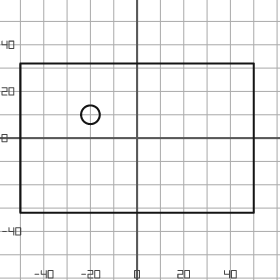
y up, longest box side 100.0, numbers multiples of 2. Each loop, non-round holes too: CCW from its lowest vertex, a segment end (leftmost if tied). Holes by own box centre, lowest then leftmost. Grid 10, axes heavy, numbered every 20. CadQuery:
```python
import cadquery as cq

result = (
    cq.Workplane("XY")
    .moveTo(-50.0, -32.0)
    .lineTo(50.0, -32.0)
    .lineTo(50.0, 32.0)
    .lineTo(-50.0, 32.0)
    .close()
    .moveTo(-20.0, 10.0)
    .circle(4.0)
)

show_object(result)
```